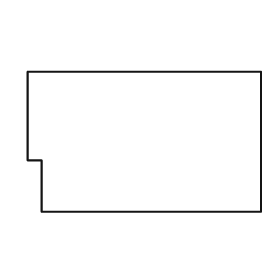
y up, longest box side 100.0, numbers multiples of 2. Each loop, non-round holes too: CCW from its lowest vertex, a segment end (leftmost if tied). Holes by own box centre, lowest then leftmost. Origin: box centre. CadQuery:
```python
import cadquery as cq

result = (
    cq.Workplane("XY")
    .moveTo(-44.0, -30.0)
    .lineTo(50.0, -30.0)
    .lineTo(50.0, 30.0)
    .lineTo(-50.0, 30.0)
    .lineTo(-50.0, -8.0)
    .lineTo(-44.0, -8.0)
    .close()
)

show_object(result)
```